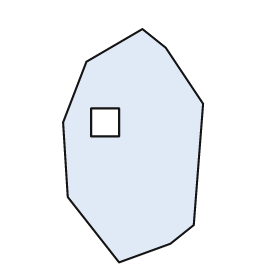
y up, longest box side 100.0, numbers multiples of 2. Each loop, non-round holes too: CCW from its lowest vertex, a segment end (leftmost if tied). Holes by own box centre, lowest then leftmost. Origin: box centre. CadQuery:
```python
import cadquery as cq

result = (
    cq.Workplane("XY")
    .moveTo(-6.0, -50.0)
    .lineTo(16.0, -42.0)
    .lineTo(26.0, -34.0)
    .lineTo(30.0, 18.0)
    .lineTo(14.0, 42.0)
    .lineTo(4.0, 50.0)
    .lineTo(-20.0, 36.0)
    .lineTo(-30.0, 10.0)
    .lineTo(-28.0, -22.0)
    .close()
    .moveTo(-18.0, 4.0)
    .lineTo(-6.0, 4.0)
    .lineTo(-6.0, 16.0)
    .lineTo(-18.0, 16.0)
    .close()
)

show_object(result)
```